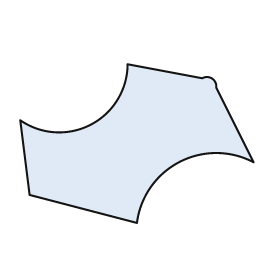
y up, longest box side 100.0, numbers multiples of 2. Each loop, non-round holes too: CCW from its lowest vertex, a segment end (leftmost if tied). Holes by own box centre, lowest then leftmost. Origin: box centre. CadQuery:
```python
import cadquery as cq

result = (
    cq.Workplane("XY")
    .moveTo(0.0, -34.0)
    .threePointArc((18.0, -8.0), (50.0, -8.0))
    .lineTo(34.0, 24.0)
    .threePointArc((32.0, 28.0), (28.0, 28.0))
    .lineTo(-4.0, 34.0)
    .threePointArc((-20.0, 8.0), (-50.0, 10.0))
    .lineTo(-46.0, -22.0)
    .close()
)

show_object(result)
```